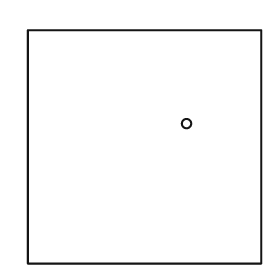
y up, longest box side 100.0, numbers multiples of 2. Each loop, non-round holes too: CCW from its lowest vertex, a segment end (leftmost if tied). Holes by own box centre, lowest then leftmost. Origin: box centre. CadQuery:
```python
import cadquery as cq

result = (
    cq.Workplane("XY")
    .moveTo(-50.0, -50.0)
    .lineTo(50.0, -50.0)
    .lineTo(50.0, 50.0)
    .lineTo(-50.0, 50.0)
    .close()
    .moveTo(18.0, 10.0)
    .circle(2.0)
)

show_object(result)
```